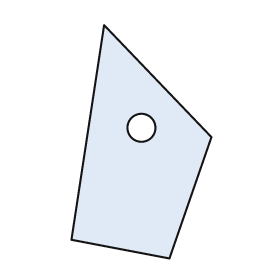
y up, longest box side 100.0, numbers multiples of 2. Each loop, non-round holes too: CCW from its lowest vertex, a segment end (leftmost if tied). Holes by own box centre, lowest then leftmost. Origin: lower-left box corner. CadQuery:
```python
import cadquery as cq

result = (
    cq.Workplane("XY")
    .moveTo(42.0, 0.0)
    .lineTo(60.0, 52.0)
    .lineTo(14.0, 100.0)
    .lineTo(0.0, 8.0)
    .close()
    .moveTo(30.0, 56.0)
    .circle(6.0)
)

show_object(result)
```